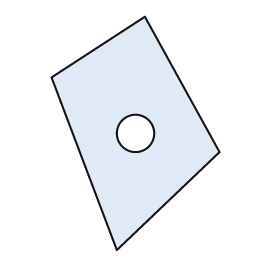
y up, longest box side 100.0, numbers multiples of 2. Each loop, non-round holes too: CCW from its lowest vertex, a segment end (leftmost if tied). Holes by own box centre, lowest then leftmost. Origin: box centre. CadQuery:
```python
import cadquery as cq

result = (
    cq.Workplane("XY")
    .moveTo(-8.0, -50.0)
    .lineTo(36.0, -8.0)
    .lineTo(4.0, 50.0)
    .lineTo(-36.0, 24.0)
    .close()
    .moveTo(0.0, 0.0)
    .circle(8.0)
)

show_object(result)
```